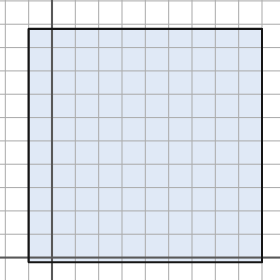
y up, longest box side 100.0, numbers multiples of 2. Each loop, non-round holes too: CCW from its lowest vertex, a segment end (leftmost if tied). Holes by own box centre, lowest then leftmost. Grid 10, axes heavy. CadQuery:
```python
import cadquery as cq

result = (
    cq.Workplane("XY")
    .moveTo(-10.0, -2.0)
    .lineTo(90.0, -2.0)
    .lineTo(90.0, 98.0)
    .lineTo(-10.0, 98.0)
    .close()
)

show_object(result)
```